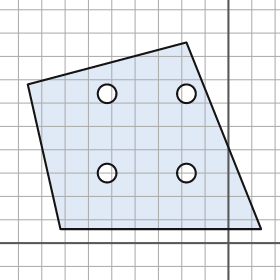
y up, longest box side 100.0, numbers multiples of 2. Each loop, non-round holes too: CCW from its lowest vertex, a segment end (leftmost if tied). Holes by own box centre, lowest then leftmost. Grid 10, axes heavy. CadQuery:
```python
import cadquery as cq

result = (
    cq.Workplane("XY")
    .moveTo(-72.0, 6.0)
    .lineTo(14.0, 6.0)
    .lineTo(-18.0, 86.0)
    .lineTo(-86.0, 68.0)
    .close()
    .moveTo(-52.0, 30.0)
    .circle(4.0)
    .moveTo(-18.0, 30.0)
    .circle(4.0)
    .moveTo(-52.0, 64.0)
    .circle(4.0)
    .moveTo(-18.0, 64.0)
    .circle(4.0)
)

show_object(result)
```